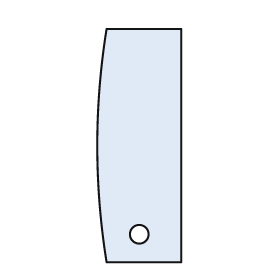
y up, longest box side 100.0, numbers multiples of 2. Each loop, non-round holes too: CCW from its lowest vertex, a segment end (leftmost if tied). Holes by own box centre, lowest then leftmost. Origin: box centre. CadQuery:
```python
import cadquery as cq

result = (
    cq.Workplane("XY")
    .moveTo(-14.0, -50.0)
    .lineTo(18.0, -50.0)
    .lineTo(18.0, 50.0)
    .lineTo(-14.0, 50.0)
    .threePointArc((-18.0, 0.0), (-14.0, -50.0))
    .close()
    .moveTo(0.0, -38.0)
    .circle(4.0)
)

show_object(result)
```